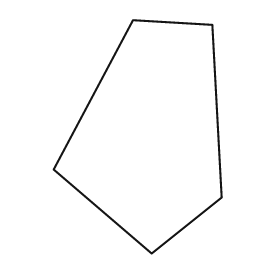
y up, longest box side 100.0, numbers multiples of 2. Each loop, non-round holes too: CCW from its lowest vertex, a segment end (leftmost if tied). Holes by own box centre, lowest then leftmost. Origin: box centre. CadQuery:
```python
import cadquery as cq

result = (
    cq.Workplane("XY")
    .moveTo(6.0, -50.0)
    .lineTo(36.0, -26.0)
    .lineTo(32.0, 48.0)
    .lineTo(-2.0, 50.0)
    .lineTo(-36.0, -14.0)
    .close()
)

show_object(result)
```